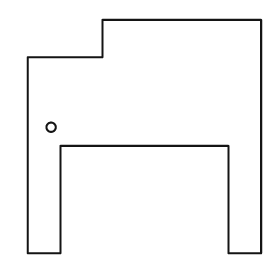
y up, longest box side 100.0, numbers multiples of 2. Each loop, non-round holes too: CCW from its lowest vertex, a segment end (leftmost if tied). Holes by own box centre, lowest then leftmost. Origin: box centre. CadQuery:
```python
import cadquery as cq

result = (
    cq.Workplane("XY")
    .moveTo(-50.0, -50.0)
    .lineTo(-36.0, -50.0)
    .lineTo(-36.0, -4.0)
    .lineTo(36.0, -4.0)
    .lineTo(36.0, -50.0)
    .lineTo(50.0, -50.0)
    .lineTo(50.0, 50.0)
    .lineTo(-18.0, 50.0)
    .lineTo(-18.0, 34.0)
    .lineTo(-50.0, 34.0)
    .close()
    .moveTo(-40.0, 4.0)
    .circle(2.0)
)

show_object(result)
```